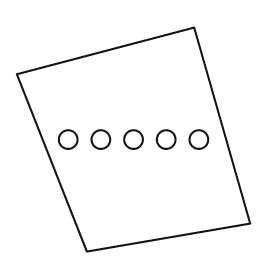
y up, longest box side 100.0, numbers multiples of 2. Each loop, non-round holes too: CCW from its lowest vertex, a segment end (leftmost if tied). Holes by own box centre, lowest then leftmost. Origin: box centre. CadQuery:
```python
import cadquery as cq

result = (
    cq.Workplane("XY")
    .moveTo(-20.0, -48.0)
    .lineTo(50.0, -36.0)
    .lineTo(26.0, 48.0)
    .lineTo(-50.0, 28.0)
    .close()
    .moveTo(-28.0, 0.0)
    .circle(4.0)
    .moveTo(-14.0, 0.0)
    .circle(4.0)
    .moveTo(0.0, 0.0)
    .circle(4.0)
    .moveTo(14.0, 0.0)
    .circle(4.0)
    .moveTo(28.0, 0.0)
    .circle(4.0)
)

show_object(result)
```